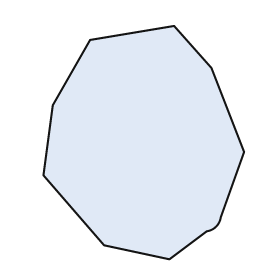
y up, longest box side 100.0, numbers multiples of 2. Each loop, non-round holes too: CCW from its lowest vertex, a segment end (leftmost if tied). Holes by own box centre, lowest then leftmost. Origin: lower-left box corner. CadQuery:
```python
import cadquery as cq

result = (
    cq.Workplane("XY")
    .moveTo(54.0, 0.0)
    .lineTo(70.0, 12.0)
    .threePointArc((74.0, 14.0), (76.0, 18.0))
    .lineTo(86.0, 46.0)
    .lineTo(72.0, 82.0)
    .lineTo(56.0, 100.0)
    .lineTo(20.0, 94.0)
    .lineTo(4.0, 66.0)
    .lineTo(0.0, 36.0)
    .lineTo(26.0, 6.0)
    .close()
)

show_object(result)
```